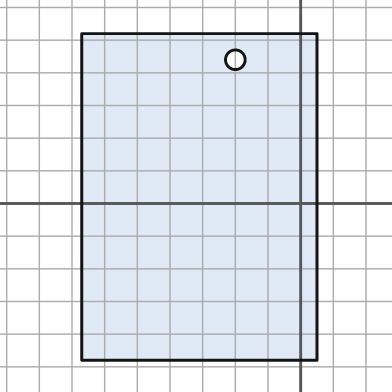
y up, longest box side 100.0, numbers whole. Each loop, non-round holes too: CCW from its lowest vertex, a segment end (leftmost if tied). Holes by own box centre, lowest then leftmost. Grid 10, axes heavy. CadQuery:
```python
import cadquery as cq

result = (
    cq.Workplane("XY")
    .moveTo(-67.0, -48.0)
    .lineTo(5.0, -48.0)
    .lineTo(5.0, 52.0)
    .lineTo(-67.0, 52.0)
    .close()
    .moveTo(-20.0, 44.0)
    .circle(3.0)
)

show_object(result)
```